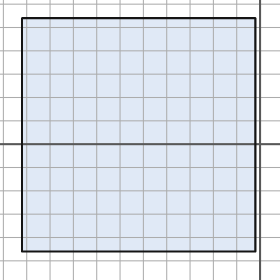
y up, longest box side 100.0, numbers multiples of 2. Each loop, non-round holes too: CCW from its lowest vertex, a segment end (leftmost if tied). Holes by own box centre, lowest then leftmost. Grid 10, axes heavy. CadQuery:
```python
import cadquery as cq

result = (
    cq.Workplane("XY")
    .moveTo(-102.0, -46.0)
    .lineTo(-2.0, -46.0)
    .lineTo(-2.0, 54.0)
    .lineTo(-102.0, 54.0)
    .close()
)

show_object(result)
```